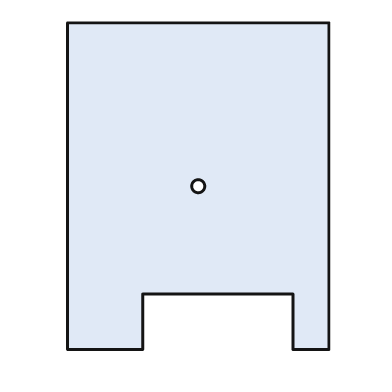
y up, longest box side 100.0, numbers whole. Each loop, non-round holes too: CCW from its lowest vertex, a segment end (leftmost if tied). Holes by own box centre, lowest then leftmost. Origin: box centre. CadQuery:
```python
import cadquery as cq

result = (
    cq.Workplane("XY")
    .moveTo(-40.0, -50.0)
    .lineTo(-17.0, -50.0)
    .lineTo(-17.0, -33.0)
    .lineTo(29.0, -33.0)
    .lineTo(29.0, -50.0)
    .lineTo(40.0, -50.0)
    .lineTo(40.0, 50.0)
    .lineTo(-40.0, 50.0)
    .close()
    .moveTo(0.0, 0.0)
    .circle(2.0)
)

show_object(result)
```